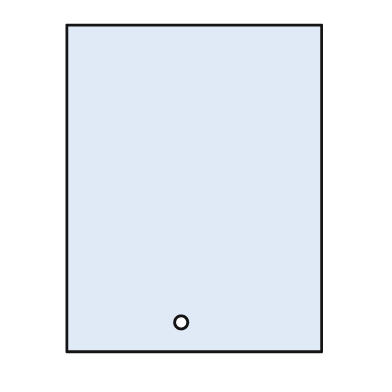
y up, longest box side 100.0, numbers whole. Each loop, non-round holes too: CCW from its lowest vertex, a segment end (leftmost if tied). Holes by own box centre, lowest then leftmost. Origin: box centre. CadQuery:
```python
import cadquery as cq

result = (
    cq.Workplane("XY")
    .moveTo(-39.0, -50.0)
    .lineTo(39.0, -50.0)
    .lineTo(39.0, 50.0)
    .lineTo(-39.0, 50.0)
    .close()
    .moveTo(-4.0, -41.0)
    .circle(2.0)
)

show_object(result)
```